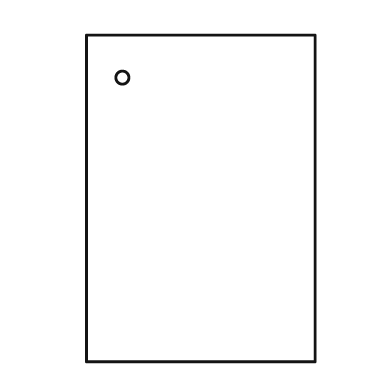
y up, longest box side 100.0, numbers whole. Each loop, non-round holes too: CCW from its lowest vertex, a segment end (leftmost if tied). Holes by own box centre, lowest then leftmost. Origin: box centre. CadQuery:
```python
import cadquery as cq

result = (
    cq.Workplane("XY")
    .moveTo(-35.0, -50.0)
    .lineTo(35.0, -50.0)
    .lineTo(35.0, 50.0)
    .lineTo(-35.0, 50.0)
    .close()
    .moveTo(-24.0, 37.0)
    .circle(2.0)
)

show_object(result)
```